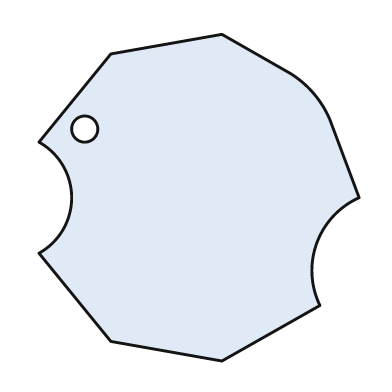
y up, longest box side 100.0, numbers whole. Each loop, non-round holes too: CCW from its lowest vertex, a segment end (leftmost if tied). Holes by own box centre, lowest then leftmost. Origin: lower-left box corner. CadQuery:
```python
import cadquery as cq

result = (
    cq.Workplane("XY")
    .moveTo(56.0, 0.0)
    .lineTo(86.0, 17.0)
    .threePointArc((85.0, 36.0), (98.0, 50.0))
    .lineTo(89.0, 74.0)
    .threePointArc((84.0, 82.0), (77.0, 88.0))
    .lineTo(56.0, 100.0)
    .lineTo(22.0, 94.0)
    .lineTo(0.0, 67.0)
    .threePointArc((10.0, 50.0), (0.0, 33.0))
    .lineTo(22.0, 6.0)
    .close()
    .moveTo(14.0, 71.0)
    .circle(4.0)
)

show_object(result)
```